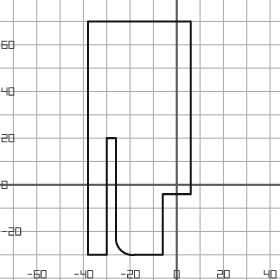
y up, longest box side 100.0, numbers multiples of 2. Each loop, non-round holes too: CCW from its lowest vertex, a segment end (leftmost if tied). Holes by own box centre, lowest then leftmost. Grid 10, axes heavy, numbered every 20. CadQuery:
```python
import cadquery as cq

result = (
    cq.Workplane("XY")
    .moveTo(-38.0, -30.0)
    .lineTo(-30.0, -30.0)
    .lineTo(-30.0, 20.0)
    .lineTo(-26.0, 20.0)
    .lineTo(-26.0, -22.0)
    .threePointArc((-24.0, -28.0), (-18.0, -30.0))
    .lineTo(-6.0, -30.0)
    .lineTo(-6.0, -4.0)
    .lineTo(6.0, -4.0)
    .lineTo(6.0, 70.0)
    .lineTo(-38.0, 70.0)
    .close()
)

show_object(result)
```